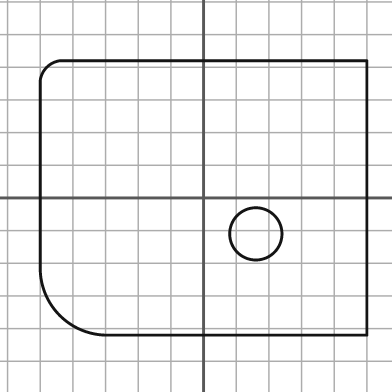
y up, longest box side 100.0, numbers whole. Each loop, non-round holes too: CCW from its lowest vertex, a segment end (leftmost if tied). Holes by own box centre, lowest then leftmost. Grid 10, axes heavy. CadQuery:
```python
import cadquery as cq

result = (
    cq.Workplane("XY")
    .moveTo(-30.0, -42.0)
    .lineTo(50.0, -42.0)
    .lineTo(50.0, 42.0)
    .lineTo(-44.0, 42.0)
    .threePointArc((-48.0, 40.0), (-50.0, 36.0))
    .lineTo(-50.0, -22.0)
    .threePointArc((-44.0, -36.0), (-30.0, -42.0))
    .close()
    .moveTo(16.0, -11.0)
    .circle(8.0)
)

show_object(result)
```